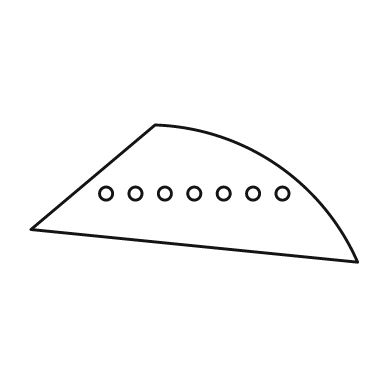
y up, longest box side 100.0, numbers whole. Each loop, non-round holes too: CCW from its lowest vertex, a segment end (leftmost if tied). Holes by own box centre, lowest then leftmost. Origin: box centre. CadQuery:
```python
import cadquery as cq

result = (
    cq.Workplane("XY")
    .moveTo(50.0, -21.0)
    .threePointArc((25.0, 9.0), (-12.0, 21.0))
    .lineTo(-50.0, -11.0)
    .close()
    .moveTo(-27.0, 0.0)
    .circle(2.0)
    .moveTo(-18.0, 0.0)
    .circle(2.0)
    .moveTo(-9.0, 0.0)
    .circle(2.0)
    .moveTo(0.0, 0.0)
    .circle(2.0)
    .moveTo(9.0, 0.0)
    .circle(2.0)
    .moveTo(18.0, 0.0)
    .circle(2.0)
    .moveTo(27.0, 0.0)
    .circle(2.0)
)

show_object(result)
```